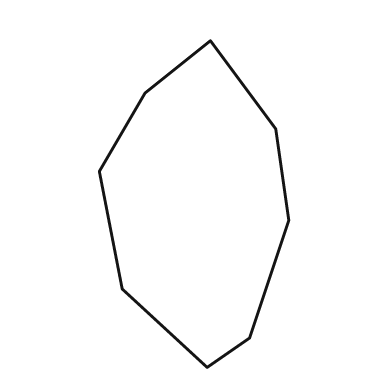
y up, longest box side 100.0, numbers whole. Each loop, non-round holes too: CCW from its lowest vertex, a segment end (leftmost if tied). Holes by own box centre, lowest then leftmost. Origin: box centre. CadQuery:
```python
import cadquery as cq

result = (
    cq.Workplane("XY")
    .moveTo(4.0, -50.0)
    .lineTo(17.0, -41.0)
    .lineTo(29.0, -5.0)
    .lineTo(25.0, 23.0)
    .lineTo(5.0, 50.0)
    .lineTo(-15.0, 34.0)
    .lineTo(-29.0, 10.0)
    .lineTo(-22.0, -26.0)
    .close()
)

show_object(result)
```